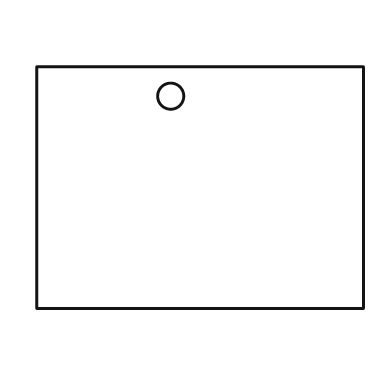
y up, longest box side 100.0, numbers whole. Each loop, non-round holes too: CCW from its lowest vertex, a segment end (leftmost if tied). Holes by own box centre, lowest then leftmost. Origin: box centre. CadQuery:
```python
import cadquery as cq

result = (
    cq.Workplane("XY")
    .moveTo(-50.0, -37.0)
    .lineTo(50.0, -37.0)
    .lineTo(50.0, 37.0)
    .lineTo(-50.0, 37.0)
    .close()
    .moveTo(-9.0, 28.0)
    .circle(4.0)
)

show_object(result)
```